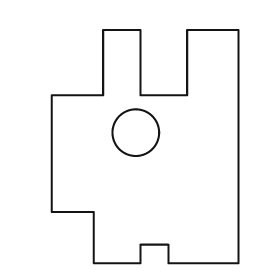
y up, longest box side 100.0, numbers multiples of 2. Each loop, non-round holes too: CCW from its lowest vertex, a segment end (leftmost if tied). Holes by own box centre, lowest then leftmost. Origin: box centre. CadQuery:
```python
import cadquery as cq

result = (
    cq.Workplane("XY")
    .moveTo(-22.0, -50.0)
    .lineTo(-2.0, -50.0)
    .lineTo(-2.0, -42.0)
    .lineTo(10.0, -42.0)
    .lineTo(10.0, -50.0)
    .lineTo(40.0, -50.0)
    .lineTo(40.0, 50.0)
    .lineTo(18.0, 50.0)
    .lineTo(18.0, 22.0)
    .lineTo(-2.0, 22.0)
    .lineTo(-2.0, 50.0)
    .lineTo(-18.0, 50.0)
    .lineTo(-18.0, 22.0)
    .lineTo(-40.0, 22.0)
    .lineTo(-40.0, -28.0)
    .lineTo(-22.0, -28.0)
    .close()
    .moveTo(-4.0, 6.0)
    .circle(10.0)
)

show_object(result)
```